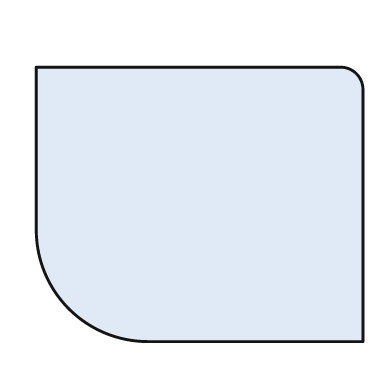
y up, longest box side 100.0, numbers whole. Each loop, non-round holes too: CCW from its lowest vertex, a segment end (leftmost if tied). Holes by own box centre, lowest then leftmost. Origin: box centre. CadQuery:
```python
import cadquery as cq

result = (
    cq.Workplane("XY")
    .moveTo(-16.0, -42.0)
    .lineTo(50.0, -42.0)
    .lineTo(50.0, 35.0)
    .threePointArc((48.0, 40.0), (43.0, 42.0))
    .lineTo(-50.0, 42.0)
    .lineTo(-50.0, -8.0)
    .threePointArc((-40.0, -32.0), (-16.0, -42.0))
    .close()
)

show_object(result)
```